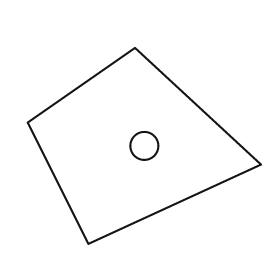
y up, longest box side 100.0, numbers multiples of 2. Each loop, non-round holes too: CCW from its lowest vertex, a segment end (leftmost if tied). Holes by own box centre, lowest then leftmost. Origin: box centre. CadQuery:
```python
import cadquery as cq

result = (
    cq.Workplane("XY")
    .moveTo(-24.0, -42.0)
    .lineTo(50.0, -8.0)
    .lineTo(-4.0, 42.0)
    .lineTo(-50.0, 10.0)
    .close()
    .moveTo(0.0, 0.0)
    .circle(6.0)
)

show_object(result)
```